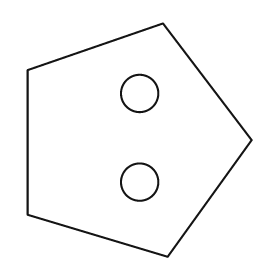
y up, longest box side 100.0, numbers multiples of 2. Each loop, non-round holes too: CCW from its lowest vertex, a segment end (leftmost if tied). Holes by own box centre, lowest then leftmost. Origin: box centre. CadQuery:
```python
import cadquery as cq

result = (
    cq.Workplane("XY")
    .moveTo(12.0, -50.0)
    .lineTo(48.0, 0.0)
    .lineTo(10.0, 50.0)
    .lineTo(-48.0, 30.0)
    .lineTo(-48.0, -32.0)
    .close()
    .moveTo(0.0, -18.0)
    .circle(8.0)
    .moveTo(0.0, 20.0)
    .circle(8.0)
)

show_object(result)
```